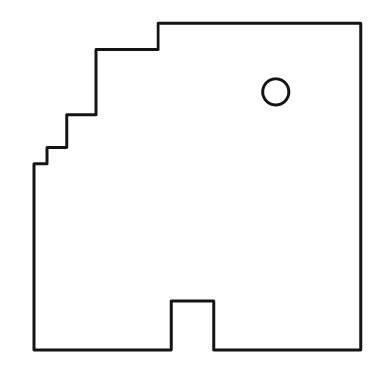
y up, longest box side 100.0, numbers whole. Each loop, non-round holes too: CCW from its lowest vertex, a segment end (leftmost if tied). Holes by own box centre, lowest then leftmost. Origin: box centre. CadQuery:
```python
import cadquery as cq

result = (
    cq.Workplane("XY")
    .moveTo(-50.0, -50.0)
    .lineTo(-8.0, -50.0)
    .lineTo(-8.0, -35.0)
    .lineTo(5.0, -35.0)
    .lineTo(5.0, -50.0)
    .lineTo(50.0, -50.0)
    .lineTo(50.0, 50.0)
    .lineTo(-12.0, 50.0)
    .lineTo(-12.0, 42.0)
    .lineTo(-31.0, 42.0)
    .lineTo(-31.0, 22.0)
    .lineTo(-40.0, 22.0)
    .lineTo(-40.0, 12.0)
    .lineTo(-46.0, 12.0)
    .lineTo(-46.0, 7.0)
    .lineTo(-50.0, 7.0)
    .close()
    .moveTo(24.0, 29.0)
    .circle(4.0)
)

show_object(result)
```